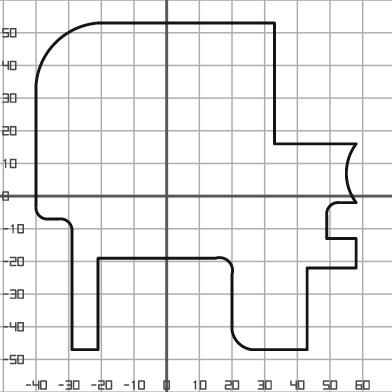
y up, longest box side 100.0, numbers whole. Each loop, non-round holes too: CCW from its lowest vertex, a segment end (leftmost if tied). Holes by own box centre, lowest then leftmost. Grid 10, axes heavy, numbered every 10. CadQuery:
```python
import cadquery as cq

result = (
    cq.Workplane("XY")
    .moveTo(-29.0, -47.0)
    .lineTo(-21.0, -47.0)
    .lineTo(-21.0, -19.0)
    .lineTo(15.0, -19.0)
    .threePointArc((19.0, -20.0), (20.0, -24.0))
    .lineTo(20.0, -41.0)
    .threePointArc((22.0, -45.0), (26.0, -47.0))
    .lineTo(43.0, -47.0)
    .lineTo(43.0, -22.0)
    .lineTo(58.0, -22.0)
    .lineTo(58.0, -13.0)
    .lineTo(49.0, -13.0)
    .lineTo(49.0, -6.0)
    .threePointArc((50.0, -3.0), (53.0, -2.0))
    .lineTo(58.0, -2.0)
    .threePointArc((55.0, 7.0), (58.0, 16.0))
    .lineTo(33.0, 16.0)
    .lineTo(33.0, 53.0)
    .lineTo(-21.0, 53.0)
    .threePointArc((-34.0, 47.0), (-40.0, 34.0))
    .lineTo(-40.0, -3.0)
    .threePointArc((-39.0, -6.0), (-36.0, -7.0))
    .lineTo(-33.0, -7.0)
    .threePointArc((-30.0, -8.0), (-29.0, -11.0))
    .close()
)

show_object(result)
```